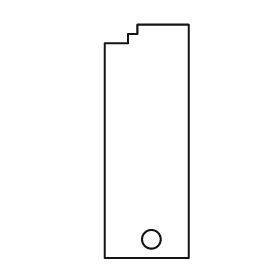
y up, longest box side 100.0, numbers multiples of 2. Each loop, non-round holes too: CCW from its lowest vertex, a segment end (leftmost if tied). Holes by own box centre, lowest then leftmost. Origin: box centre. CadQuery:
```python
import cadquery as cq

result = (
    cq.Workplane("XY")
    .moveTo(-18.0, -50.0)
    .lineTo(18.0, -50.0)
    .lineTo(18.0, 50.0)
    .lineTo(-4.0, 50.0)
    .lineTo(-4.0, 46.0)
    .lineTo(-8.0, 46.0)
    .lineTo(-8.0, 42.0)
    .lineTo(-18.0, 42.0)
    .close()
    .moveTo(2.0, -42.0)
    .circle(4.0)
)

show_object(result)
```